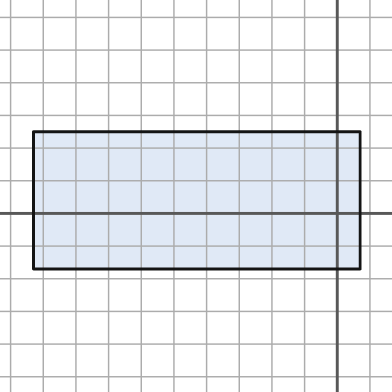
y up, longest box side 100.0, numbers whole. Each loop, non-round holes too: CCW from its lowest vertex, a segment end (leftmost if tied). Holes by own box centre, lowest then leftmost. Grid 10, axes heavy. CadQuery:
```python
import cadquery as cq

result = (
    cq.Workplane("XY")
    .moveTo(-93.0, -17.0)
    .lineTo(7.0, -17.0)
    .lineTo(7.0, 25.0)
    .lineTo(-93.0, 25.0)
    .close()
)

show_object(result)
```